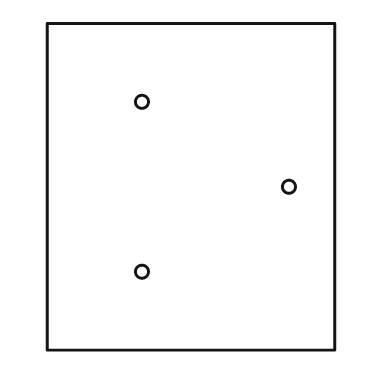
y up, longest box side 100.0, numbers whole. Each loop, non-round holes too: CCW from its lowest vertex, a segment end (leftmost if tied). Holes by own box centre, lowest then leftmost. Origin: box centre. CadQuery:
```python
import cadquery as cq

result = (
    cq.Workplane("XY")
    .moveTo(-44.0, -50.0)
    .lineTo(44.0, -50.0)
    .lineTo(44.0, 50.0)
    .lineTo(-44.0, 50.0)
    .close()
    .moveTo(-15.0, -26.0)
    .circle(2.0)
    .moveTo(30.0, 0.0)
    .circle(2.0)
    .moveTo(-15.0, 26.0)
    .circle(2.0)
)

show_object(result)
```